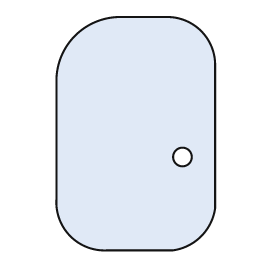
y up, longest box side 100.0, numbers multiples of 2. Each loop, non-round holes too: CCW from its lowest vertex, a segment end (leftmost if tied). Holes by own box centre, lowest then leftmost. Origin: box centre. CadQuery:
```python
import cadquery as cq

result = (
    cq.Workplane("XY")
    .moveTo(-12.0, -50.0)
    .lineTo(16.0, -50.0)
    .threePointArc((28.0, -44.0), (34.0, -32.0))
    .lineTo(34.0, 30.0)
    .threePointArc((28.0, 44.0), (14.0, 50.0))
    .lineTo(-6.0, 50.0)
    .threePointArc((-26.0, 42.0), (-34.0, 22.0))
    .lineTo(-34.0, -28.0)
    .threePointArc((-28.0, -44.0), (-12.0, -50.0))
    .close()
    .moveTo(20.0, -10.0)
    .circle(4.0)
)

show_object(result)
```